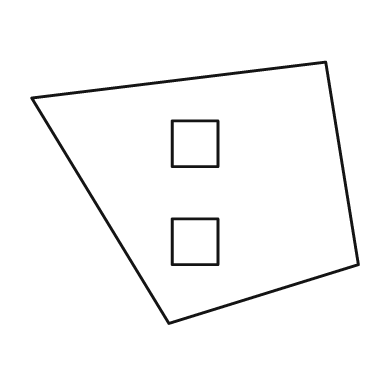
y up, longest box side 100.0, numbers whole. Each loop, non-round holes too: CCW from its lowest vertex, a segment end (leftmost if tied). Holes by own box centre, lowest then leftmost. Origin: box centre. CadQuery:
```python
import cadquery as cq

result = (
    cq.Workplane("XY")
    .moveTo(-8.0, -40.0)
    .lineTo(50.0, -22.0)
    .lineTo(40.0, 40.0)
    .lineTo(-50.0, 29.0)
    .close()
    .moveTo(-7.0, -22.0)
    .lineTo(7.0, -22.0)
    .lineTo(7.0, -8.0)
    .lineTo(-7.0, -8.0)
    .close()
    .moveTo(-7.0, 8.0)
    .lineTo(7.0, 8.0)
    .lineTo(7.0, 22.0)
    .lineTo(-7.0, 22.0)
    .close()
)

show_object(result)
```